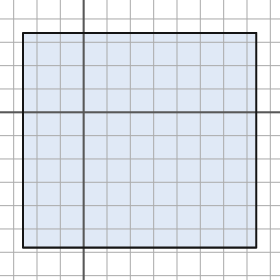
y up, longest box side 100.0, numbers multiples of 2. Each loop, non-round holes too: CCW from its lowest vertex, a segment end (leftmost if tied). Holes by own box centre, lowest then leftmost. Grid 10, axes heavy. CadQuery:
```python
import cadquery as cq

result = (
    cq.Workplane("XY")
    .moveTo(-26.0, -58.0)
    .lineTo(74.0, -58.0)
    .lineTo(74.0, 34.0)
    .lineTo(-26.0, 34.0)
    .close()
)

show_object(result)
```